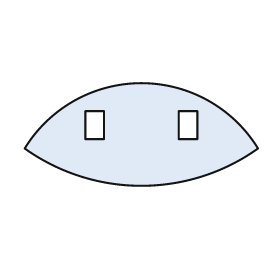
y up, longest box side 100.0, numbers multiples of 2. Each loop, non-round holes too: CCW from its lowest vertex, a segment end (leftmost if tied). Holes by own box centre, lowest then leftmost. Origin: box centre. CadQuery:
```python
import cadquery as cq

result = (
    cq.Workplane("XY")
    .moveTo(-50.0, -6.0)
    .threePointArc((0.0, -22.0), (50.0, -6.0))
    .threePointArc((0.0, 22.0), (-50.0, -6.0))
    .close()
    .moveTo(-24.0, -2.0)
    .lineTo(-16.0, -2.0)
    .lineTo(-16.0, 10.0)
    .lineTo(-24.0, 10.0)
    .close()
    .moveTo(16.0, -2.0)
    .lineTo(24.0, -2.0)
    .lineTo(24.0, 10.0)
    .lineTo(16.0, 10.0)
    .close()
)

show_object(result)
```